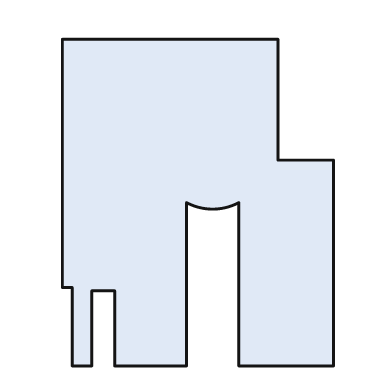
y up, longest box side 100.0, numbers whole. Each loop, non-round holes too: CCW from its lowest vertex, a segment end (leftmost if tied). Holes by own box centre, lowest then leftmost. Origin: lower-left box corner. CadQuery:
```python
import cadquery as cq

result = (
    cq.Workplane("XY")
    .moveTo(3.0, 0.0)
    .lineTo(9.0, 0.0)
    .lineTo(9.0, 23.0)
    .lineTo(16.0, 23.0)
    .lineTo(16.0, 0.0)
    .lineTo(38.0, 0.0)
    .lineTo(38.0, 50.0)
    .threePointArc((46.0, 48.0), (54.0, 50.0))
    .lineTo(54.0, 0.0)
    .lineTo(83.0, 0.0)
    .lineTo(83.0, 63.0)
    .lineTo(66.0, 63.0)
    .lineTo(66.0, 100.0)
    .lineTo(0.0, 100.0)
    .lineTo(0.0, 24.0)
    .lineTo(3.0, 24.0)
    .close()
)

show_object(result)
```